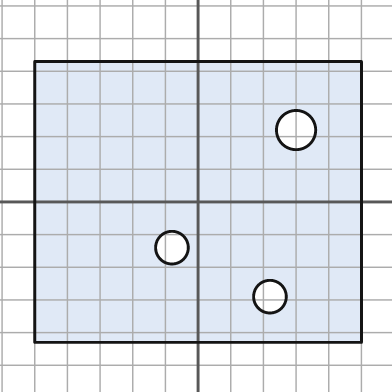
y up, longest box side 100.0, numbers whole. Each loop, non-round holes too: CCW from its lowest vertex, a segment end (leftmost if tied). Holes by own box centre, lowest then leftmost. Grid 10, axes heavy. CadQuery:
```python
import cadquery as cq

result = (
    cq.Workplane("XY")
    .moveTo(-50.0, -43.0)
    .lineTo(50.0, -43.0)
    .lineTo(50.0, 43.0)
    .lineTo(-50.0, 43.0)
    .close()
    .moveTo(22.0, -29.0)
    .circle(5.0)
    .moveTo(-8.0, -14.0)
    .circle(5.0)
    .moveTo(30.0, 22.0)
    .circle(6.0)
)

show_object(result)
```